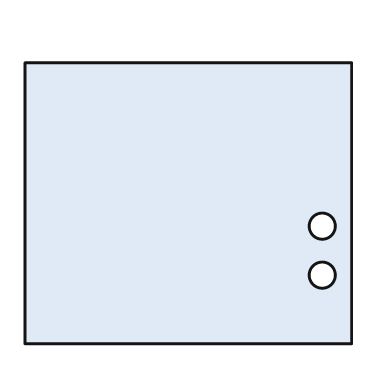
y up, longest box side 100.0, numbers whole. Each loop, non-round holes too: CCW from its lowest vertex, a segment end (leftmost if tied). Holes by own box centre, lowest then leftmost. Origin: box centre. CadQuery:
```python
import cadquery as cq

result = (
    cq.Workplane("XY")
    .moveTo(-50.0, -43.0)
    .lineTo(50.0, -43.0)
    .lineTo(50.0, 43.0)
    .lineTo(-50.0, 43.0)
    .close()
    .moveTo(41.0, -22.0)
    .circle(4.0)
    .moveTo(41.0, -7.0)
    .circle(4.0)
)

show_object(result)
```